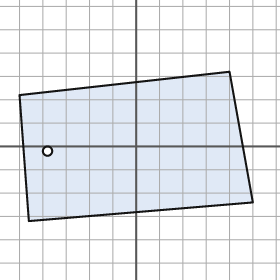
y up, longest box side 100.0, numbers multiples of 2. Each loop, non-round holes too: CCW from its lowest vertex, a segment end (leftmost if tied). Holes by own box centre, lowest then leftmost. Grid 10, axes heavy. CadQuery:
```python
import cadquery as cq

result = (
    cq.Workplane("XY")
    .moveTo(-46.0, -32.0)
    .lineTo(50.0, -24.0)
    .lineTo(40.0, 32.0)
    .lineTo(-50.0, 22.0)
    .close()
    .moveTo(-38.0, -2.0)
    .circle(2.0)
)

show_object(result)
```